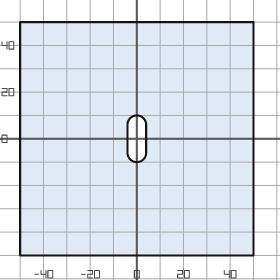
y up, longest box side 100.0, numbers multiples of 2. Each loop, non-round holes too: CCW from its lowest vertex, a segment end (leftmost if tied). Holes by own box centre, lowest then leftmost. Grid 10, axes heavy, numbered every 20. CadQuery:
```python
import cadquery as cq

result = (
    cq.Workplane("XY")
    .moveTo(-50.0, -50.0)
    .lineTo(50.0, -50.0)
    .lineTo(50.0, 50.0)
    .lineTo(-50.0, 50.0)
    .close()
    .moveTo(-4.0, -6.0)
    .threePointArc((0.0, -10.0), (4.0, -6.0))
    .lineTo(4.0, 6.0)
    .threePointArc((0.0, 10.0), (-4.0, 6.0))
    .close()
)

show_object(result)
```